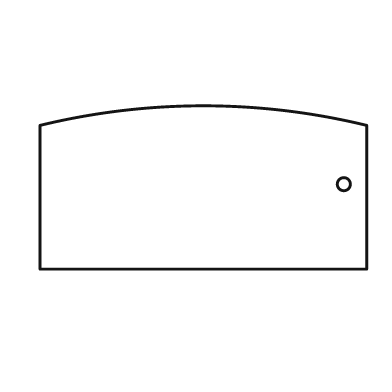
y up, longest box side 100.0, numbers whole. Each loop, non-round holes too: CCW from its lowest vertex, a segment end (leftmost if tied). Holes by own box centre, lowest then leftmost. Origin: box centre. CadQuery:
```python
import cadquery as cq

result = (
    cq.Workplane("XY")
    .moveTo(-50.0, -25.0)
    .lineTo(50.0, -25.0)
    .lineTo(50.0, 19.0)
    .threePointArc((0.0, 25.0), (-50.0, 19.0))
    .close()
    .moveTo(43.0, 1.0)
    .circle(2.0)
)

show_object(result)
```